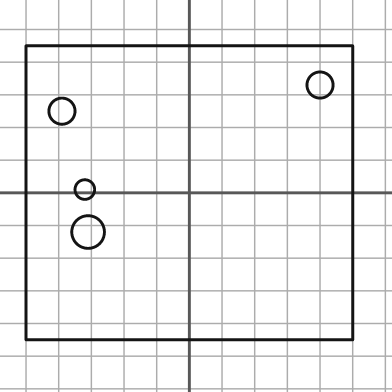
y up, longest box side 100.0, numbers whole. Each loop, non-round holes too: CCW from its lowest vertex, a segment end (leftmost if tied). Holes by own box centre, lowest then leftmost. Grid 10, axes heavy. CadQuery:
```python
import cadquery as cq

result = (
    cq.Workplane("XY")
    .moveTo(-50.0, -45.0)
    .lineTo(50.0, -45.0)
    .lineTo(50.0, 45.0)
    .lineTo(-50.0, 45.0)
    .close()
    .moveTo(-31.0, -12.0)
    .circle(5.0)
    .moveTo(-32.0, 1.0)
    .circle(3.0)
    .moveTo(-39.0, 25.0)
    .circle(4.0)
    .moveTo(40.0, 33.0)
    .circle(4.0)
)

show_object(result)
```